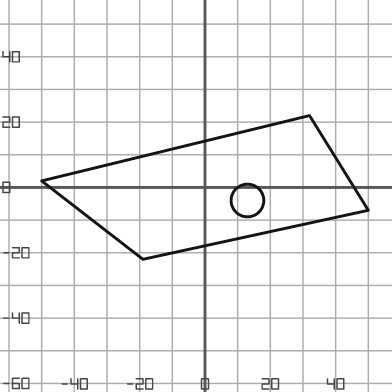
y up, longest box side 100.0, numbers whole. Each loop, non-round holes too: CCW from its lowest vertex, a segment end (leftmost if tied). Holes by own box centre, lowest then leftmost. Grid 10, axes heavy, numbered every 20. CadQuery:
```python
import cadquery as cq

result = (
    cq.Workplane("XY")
    .moveTo(-19.0, -22.0)
    .lineTo(50.0, -7.0)
    .lineTo(32.0, 22.0)
    .lineTo(-50.0, 2.0)
    .close()
    .moveTo(13.0, -4.0)
    .circle(5.0)
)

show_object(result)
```